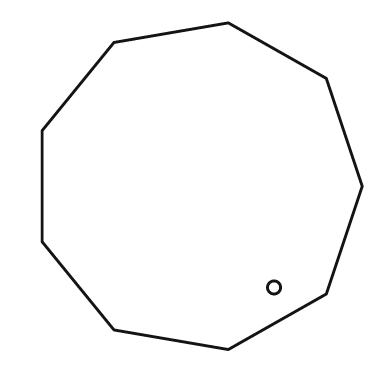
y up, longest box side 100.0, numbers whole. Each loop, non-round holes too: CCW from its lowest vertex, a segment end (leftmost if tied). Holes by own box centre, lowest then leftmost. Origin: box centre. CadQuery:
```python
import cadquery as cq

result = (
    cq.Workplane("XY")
    .moveTo(8.0, -50.0)
    .lineTo(38.0, -33.0)
    .lineTo(49.0, 0.0)
    .lineTo(38.0, 33.0)
    .lineTo(8.0, 50.0)
    .lineTo(-27.0, 44.0)
    .lineTo(-49.0, 17.0)
    .lineTo(-49.0, -17.0)
    .lineTo(-27.0, -44.0)
    .close()
    .moveTo(22.0, -31.0)
    .circle(2.0)
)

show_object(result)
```